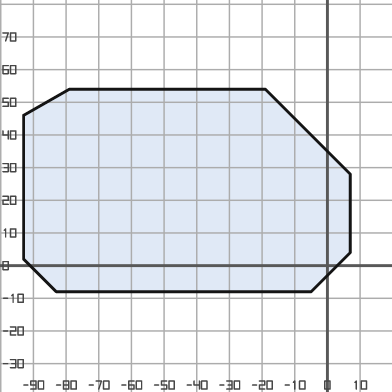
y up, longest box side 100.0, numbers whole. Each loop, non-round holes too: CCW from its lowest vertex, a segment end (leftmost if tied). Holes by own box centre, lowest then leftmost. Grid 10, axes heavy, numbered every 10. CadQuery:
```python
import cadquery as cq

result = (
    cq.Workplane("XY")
    .moveTo(-83.0, -8.0)
    .lineTo(-5.0, -8.0)
    .lineTo(7.0, 4.0)
    .lineTo(7.0, 28.0)
    .lineTo(-19.0, 54.0)
    .lineTo(-79.0, 54.0)
    .lineTo(-93.0, 46.0)
    .lineTo(-93.0, 2.0)
    .close()
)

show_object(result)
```